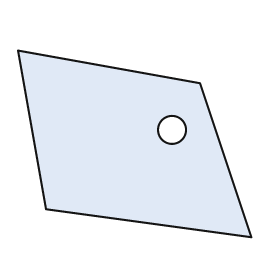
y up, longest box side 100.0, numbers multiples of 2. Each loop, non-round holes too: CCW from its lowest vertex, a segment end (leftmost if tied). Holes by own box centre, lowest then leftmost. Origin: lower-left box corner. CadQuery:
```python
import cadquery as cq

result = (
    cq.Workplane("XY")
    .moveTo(100.0, 0.0)
    .lineTo(78.0, 66.0)
    .lineTo(0.0, 80.0)
    .lineTo(12.0, 12.0)
    .close()
    .moveTo(66.0, 46.0)
    .circle(6.0)
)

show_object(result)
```